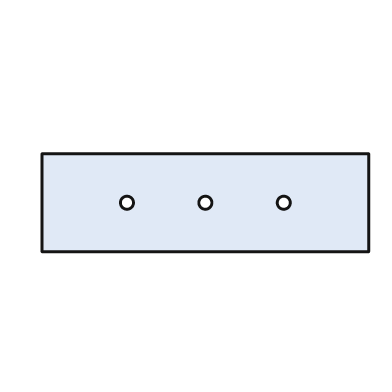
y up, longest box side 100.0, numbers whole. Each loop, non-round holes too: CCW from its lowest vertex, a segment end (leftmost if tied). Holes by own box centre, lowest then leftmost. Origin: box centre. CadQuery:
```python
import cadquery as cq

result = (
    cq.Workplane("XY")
    .moveTo(-50.0, -15.0)
    .lineTo(50.0, -15.0)
    .lineTo(50.0, 15.0)
    .lineTo(-50.0, 15.0)
    .close()
    .moveTo(-24.0, 0.0)
    .circle(2.0)
    .moveTo(0.0, 0.0)
    .circle(2.0)
    .moveTo(24.0, 0.0)
    .circle(2.0)
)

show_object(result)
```